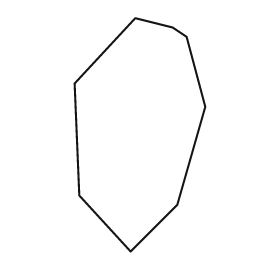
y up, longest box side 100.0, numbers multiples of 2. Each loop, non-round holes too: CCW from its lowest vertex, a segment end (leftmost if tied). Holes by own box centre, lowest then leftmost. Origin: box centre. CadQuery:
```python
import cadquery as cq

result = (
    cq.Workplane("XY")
    .moveTo(-4.0, -50.0)
    .lineTo(16.0, -30.0)
    .lineTo(28.0, 12.0)
    .lineTo(20.0, 42.0)
    .lineTo(14.0, 46.0)
    .lineTo(-2.0, 50.0)
    .lineTo(-28.0, 22.0)
    .lineTo(-26.0, -26.0)
    .close()
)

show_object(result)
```